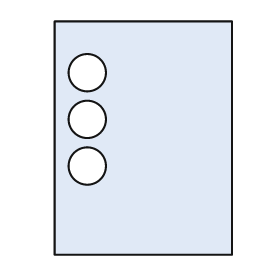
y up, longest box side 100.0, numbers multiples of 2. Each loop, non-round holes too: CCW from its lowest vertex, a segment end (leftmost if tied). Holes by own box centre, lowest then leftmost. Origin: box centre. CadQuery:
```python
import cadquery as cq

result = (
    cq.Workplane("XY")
    .moveTo(-38.0, -50.0)
    .lineTo(38.0, -50.0)
    .lineTo(38.0, 50.0)
    .lineTo(-38.0, 50.0)
    .close()
    .moveTo(-24.0, -12.0)
    .circle(8.0)
    .moveTo(-24.0, 8.0)
    .circle(8.0)
    .moveTo(-24.0, 28.0)
    .circle(8.0)
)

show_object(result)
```